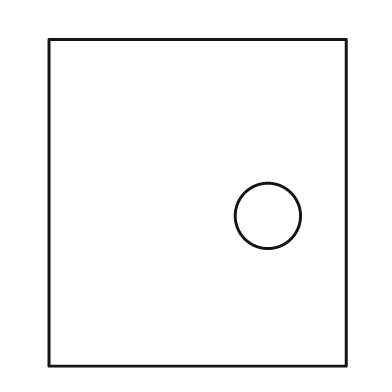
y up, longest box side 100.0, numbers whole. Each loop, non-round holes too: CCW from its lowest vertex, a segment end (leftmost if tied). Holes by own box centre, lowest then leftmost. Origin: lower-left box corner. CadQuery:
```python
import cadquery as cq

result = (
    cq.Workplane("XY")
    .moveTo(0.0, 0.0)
    .lineTo(91.0, 0.0)
    .lineTo(91.0, 100.0)
    .lineTo(0.0, 100.0)
    .close()
    .moveTo(67.0, 46.0)
    .circle(10.0)
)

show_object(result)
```